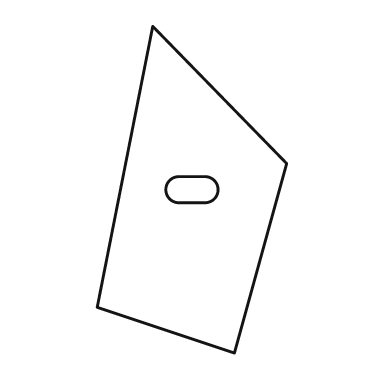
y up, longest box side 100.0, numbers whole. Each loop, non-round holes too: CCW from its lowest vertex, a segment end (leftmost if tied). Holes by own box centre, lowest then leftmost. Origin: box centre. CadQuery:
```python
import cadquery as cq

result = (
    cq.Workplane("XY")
    .moveTo(13.0, -50.0)
    .lineTo(29.0, 8.0)
    .lineTo(-12.0, 50.0)
    .lineTo(-29.0, -36.0)
    .close()
    .moveTo(-4.0, -4.0)
    .lineTo(4.0, -4.0)
    .threePointArc((8.0, 0.0), (4.0, 4.0))
    .lineTo(-4.0, 4.0)
    .threePointArc((-8.0, 0.0), (-4.0, -4.0))
    .close()
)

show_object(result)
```